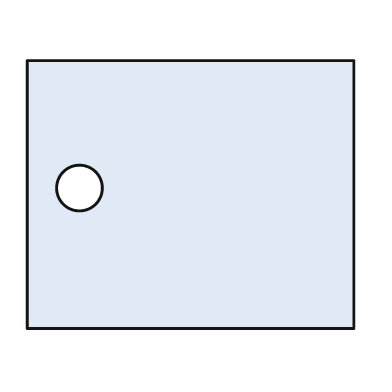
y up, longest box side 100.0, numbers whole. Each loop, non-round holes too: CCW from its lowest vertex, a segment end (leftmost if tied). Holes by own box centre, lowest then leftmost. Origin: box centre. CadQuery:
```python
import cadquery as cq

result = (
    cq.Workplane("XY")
    .moveTo(-50.0, -41.0)
    .lineTo(50.0, -41.0)
    .lineTo(50.0, 41.0)
    .lineTo(-50.0, 41.0)
    .close()
    .moveTo(-34.0, 2.0)
    .circle(7.0)
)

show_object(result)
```